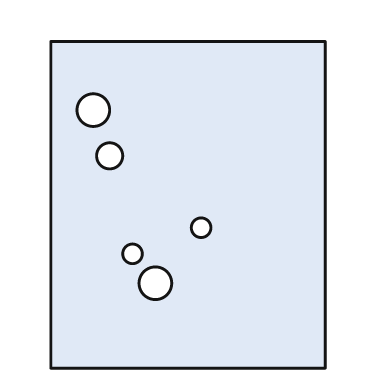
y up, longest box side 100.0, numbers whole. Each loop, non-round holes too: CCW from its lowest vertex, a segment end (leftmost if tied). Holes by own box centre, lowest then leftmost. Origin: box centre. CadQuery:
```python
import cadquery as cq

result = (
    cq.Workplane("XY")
    .moveTo(-42.0, -50.0)
    .lineTo(42.0, -50.0)
    .lineTo(42.0, 50.0)
    .lineTo(-42.0, 50.0)
    .close()
    .moveTo(-10.0, -24.0)
    .circle(5.0)
    .moveTo(-17.0, -15.0)
    .circle(3.0)
    .moveTo(4.0, -7.0)
    .circle(3.0)
    .moveTo(-24.0, 15.0)
    .circle(4.0)
    .moveTo(-29.0, 29.0)
    .circle(5.0)
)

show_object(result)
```